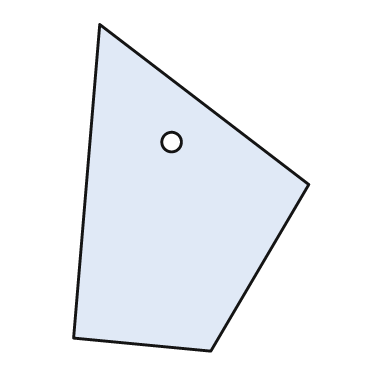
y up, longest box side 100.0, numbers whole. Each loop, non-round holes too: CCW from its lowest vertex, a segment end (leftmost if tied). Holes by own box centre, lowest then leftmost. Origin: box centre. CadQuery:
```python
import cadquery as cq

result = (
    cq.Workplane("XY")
    .moveTo(6.0, -50.0)
    .lineTo(36.0, 1.0)
    .lineTo(-28.0, 50.0)
    .lineTo(-36.0, -46.0)
    .close()
    .moveTo(-6.0, 14.0)
    .circle(3.0)
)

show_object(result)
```